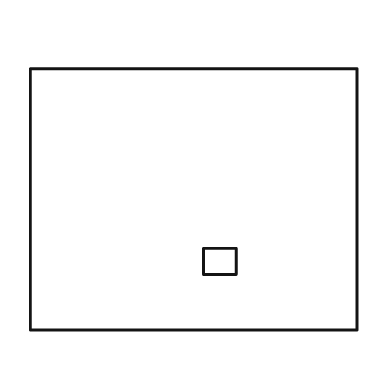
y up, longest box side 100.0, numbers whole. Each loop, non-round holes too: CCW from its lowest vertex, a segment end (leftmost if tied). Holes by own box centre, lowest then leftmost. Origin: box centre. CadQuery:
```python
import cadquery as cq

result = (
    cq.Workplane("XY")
    .moveTo(-50.0, -40.0)
    .lineTo(50.0, -40.0)
    .lineTo(50.0, 40.0)
    .lineTo(-50.0, 40.0)
    .close()
    .moveTo(3.0, -23.0)
    .lineTo(13.0, -23.0)
    .lineTo(13.0, -15.0)
    .lineTo(3.0, -15.0)
    .close()
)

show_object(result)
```